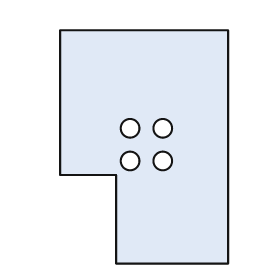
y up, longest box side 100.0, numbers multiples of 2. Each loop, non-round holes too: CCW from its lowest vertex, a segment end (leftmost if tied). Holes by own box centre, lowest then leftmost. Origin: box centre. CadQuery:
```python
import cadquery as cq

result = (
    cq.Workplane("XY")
    .moveTo(-12.0, -50.0)
    .lineTo(36.0, -50.0)
    .lineTo(36.0, 50.0)
    .lineTo(-36.0, 50.0)
    .lineTo(-36.0, -12.0)
    .lineTo(-12.0, -12.0)
    .close()
    .moveTo(-6.0, -6.0)
    .circle(4.0)
    .moveTo(8.0, -6.0)
    .circle(4.0)
    .moveTo(-6.0, 8.0)
    .circle(4.0)
    .moveTo(8.0, 8.0)
    .circle(4.0)
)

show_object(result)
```